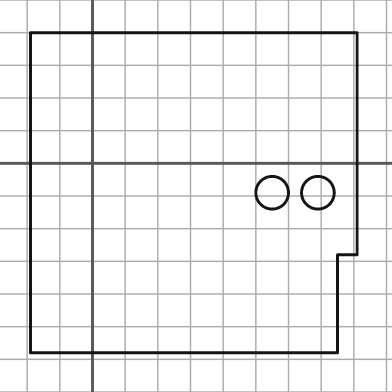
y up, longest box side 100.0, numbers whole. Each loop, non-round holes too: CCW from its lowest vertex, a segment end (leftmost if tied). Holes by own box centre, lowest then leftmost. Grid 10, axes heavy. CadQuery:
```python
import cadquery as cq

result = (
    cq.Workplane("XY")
    .moveTo(-19.0, -58.0)
    .lineTo(75.0, -58.0)
    .lineTo(75.0, -28.0)
    .lineTo(81.0, -28.0)
    .lineTo(81.0, 40.0)
    .lineTo(-19.0, 40.0)
    .close()
    .moveTo(55.0, -9.0)
    .circle(5.0)
    .moveTo(69.0, -9.0)
    .circle(5.0)
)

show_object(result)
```